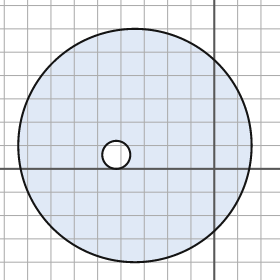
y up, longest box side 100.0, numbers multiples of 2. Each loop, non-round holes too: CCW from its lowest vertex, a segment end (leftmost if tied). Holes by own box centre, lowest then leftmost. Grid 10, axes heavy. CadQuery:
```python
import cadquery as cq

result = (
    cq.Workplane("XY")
    .moveTo(-34.0, 10.0)
    .circle(50.0)
    .moveTo(-42.0, 6.0)
    .circle(6.0)
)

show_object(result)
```